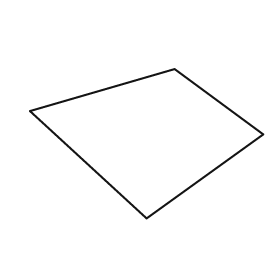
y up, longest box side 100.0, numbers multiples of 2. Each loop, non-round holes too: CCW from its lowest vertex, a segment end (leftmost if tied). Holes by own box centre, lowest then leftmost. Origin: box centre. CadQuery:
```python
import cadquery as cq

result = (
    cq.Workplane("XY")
    .moveTo(0.0, -32.0)
    .lineTo(50.0, 4.0)
    .lineTo(12.0, 32.0)
    .lineTo(-50.0, 14.0)
    .close()
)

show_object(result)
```